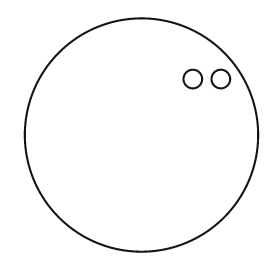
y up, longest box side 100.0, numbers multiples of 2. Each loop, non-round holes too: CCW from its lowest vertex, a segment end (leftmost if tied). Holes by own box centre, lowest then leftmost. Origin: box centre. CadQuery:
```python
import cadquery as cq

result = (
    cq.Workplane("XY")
    .moveTo(0.0, 0.0)
    .circle(50.0)
    .moveTo(22.0, 24.0)
    .circle(4.0)
    .moveTo(34.0, 24.0)
    .circle(4.0)
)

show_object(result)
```